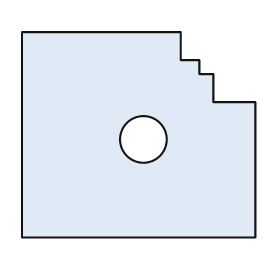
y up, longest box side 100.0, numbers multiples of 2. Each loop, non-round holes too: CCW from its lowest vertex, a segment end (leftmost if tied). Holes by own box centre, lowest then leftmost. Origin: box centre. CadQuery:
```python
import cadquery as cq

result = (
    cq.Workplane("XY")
    .moveTo(-50.0, -44.0)
    .lineTo(50.0, -44.0)
    .lineTo(50.0, 14.0)
    .lineTo(32.0, 14.0)
    .lineTo(32.0, 26.0)
    .lineTo(26.0, 26.0)
    .lineTo(26.0, 32.0)
    .lineTo(18.0, 32.0)
    .lineTo(18.0, 44.0)
    .lineTo(-50.0, 44.0)
    .close()
    .moveTo(2.0, -2.0)
    .circle(10.0)
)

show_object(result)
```